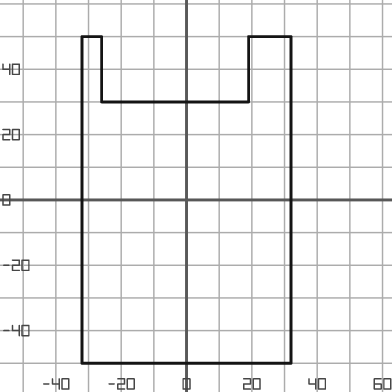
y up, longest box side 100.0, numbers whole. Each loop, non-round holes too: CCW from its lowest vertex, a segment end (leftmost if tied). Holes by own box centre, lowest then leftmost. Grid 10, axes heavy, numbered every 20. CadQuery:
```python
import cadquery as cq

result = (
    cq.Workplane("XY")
    .moveTo(-32.0, -50.0)
    .lineTo(32.0, -50.0)
    .lineTo(32.0, 50.0)
    .lineTo(19.0, 50.0)
    .lineTo(19.0, 30.0)
    .lineTo(-26.0, 30.0)
    .lineTo(-26.0, 50.0)
    .lineTo(-32.0, 50.0)
    .close()
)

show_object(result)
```